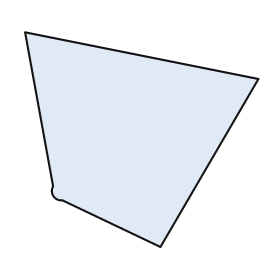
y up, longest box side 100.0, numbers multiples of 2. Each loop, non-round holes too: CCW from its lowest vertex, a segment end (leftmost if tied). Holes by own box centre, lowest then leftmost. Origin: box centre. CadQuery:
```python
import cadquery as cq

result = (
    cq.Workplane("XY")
    .moveTo(8.0, -46.0)
    .lineTo(50.0, 26.0)
    .lineTo(-50.0, 46.0)
    .lineTo(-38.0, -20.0)
    .threePointArc((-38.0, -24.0), (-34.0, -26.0))
    .close()
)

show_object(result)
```